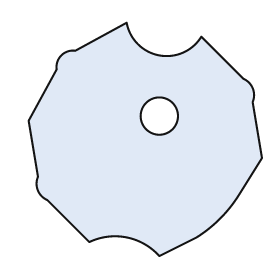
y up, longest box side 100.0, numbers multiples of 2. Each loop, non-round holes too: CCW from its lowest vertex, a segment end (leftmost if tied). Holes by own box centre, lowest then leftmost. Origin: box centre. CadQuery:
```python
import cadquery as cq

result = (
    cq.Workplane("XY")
    .moveTo(6.0, -50.0)
    .lineTo(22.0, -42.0)
    .threePointArc((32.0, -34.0), (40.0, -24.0))
    .lineTo(50.0, -8.0)
    .lineTo(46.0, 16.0)
    .threePointArc((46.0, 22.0), (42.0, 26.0))
    .lineTo(24.0, 44.0)
    .threePointArc((6.0, 36.0), (-8.0, 50.0))
    .lineTo(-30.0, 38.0)
    .threePointArc((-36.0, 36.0), (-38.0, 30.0))
    .lineTo(-50.0, 8.0)
    .lineTo(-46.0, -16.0)
    .threePointArc((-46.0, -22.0), (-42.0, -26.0))
    .lineTo(-24.0, -44.0)
    .threePointArc((-8.0, -42.0), (6.0, -50.0))
    .close()
    .moveTo(6.0, 10.0)
    .circle(8.0)
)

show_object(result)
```